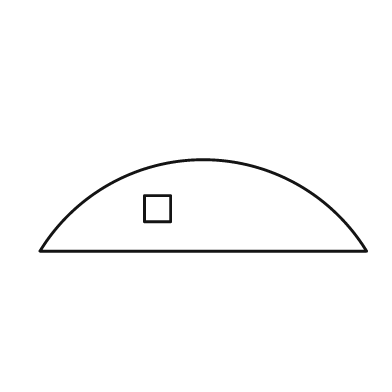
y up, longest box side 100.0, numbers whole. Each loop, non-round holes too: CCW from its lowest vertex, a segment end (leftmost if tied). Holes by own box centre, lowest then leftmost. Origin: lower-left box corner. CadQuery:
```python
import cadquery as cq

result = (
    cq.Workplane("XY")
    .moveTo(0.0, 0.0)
    .lineTo(100.0, 0.0)
    .threePointArc((50.0, 28.0), (0.0, 0.0))
    .close()
    .moveTo(32.0, 9.0)
    .lineTo(40.0, 9.0)
    .lineTo(40.0, 17.0)
    .lineTo(32.0, 17.0)
    .close()
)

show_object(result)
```